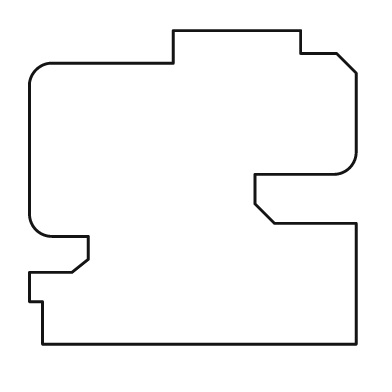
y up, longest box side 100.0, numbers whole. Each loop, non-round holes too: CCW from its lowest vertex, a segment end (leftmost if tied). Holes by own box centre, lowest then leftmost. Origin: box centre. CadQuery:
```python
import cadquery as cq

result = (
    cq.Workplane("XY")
    .moveTo(-46.0, -48.0)
    .lineTo(50.0, -48.0)
    .lineTo(50.0, -11.0)
    .lineTo(25.0, -11.0)
    .lineTo(19.0, -5.0)
    .lineTo(19.0, 4.0)
    .lineTo(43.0, 4.0)
    .threePointArc((48.0, 6.0), (50.0, 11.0))
    .lineTo(50.0, 35.0)
    .lineTo(44.0, 41.0)
    .lineTo(33.0, 41.0)
    .lineTo(33.0, 48.0)
    .lineTo(-6.0, 48.0)
    .lineTo(-6.0, 38.0)
    .lineTo(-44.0, 38.0)
    .threePointArc((-48.0, 36.0), (-50.0, 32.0))
    .lineTo(-50.0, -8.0)
    .threePointArc((-48.0, -13.0), (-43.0, -15.0))
    .lineTo(-32.0, -15.0)
    .lineTo(-32.0, -22.0)
    .lineTo(-37.0, -26.0)
    .lineTo(-50.0, -26.0)
    .lineTo(-50.0, -35.0)
    .lineTo(-46.0, -35.0)
    .close()
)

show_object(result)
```